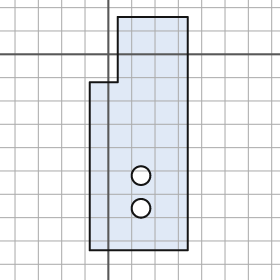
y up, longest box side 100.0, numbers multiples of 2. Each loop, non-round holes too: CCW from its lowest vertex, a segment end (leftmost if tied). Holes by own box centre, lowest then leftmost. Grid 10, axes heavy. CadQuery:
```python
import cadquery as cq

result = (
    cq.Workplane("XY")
    .moveTo(-8.0, -84.0)
    .lineTo(34.0, -84.0)
    .lineTo(34.0, 16.0)
    .lineTo(4.0, 16.0)
    .lineTo(4.0, -12.0)
    .lineTo(-8.0, -12.0)
    .close()
    .moveTo(14.0, -66.0)
    .circle(4.0)
    .moveTo(14.0, -52.0)
    .circle(4.0)
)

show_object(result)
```